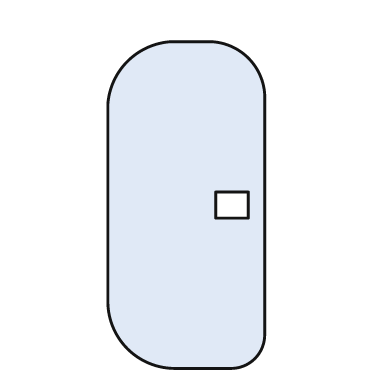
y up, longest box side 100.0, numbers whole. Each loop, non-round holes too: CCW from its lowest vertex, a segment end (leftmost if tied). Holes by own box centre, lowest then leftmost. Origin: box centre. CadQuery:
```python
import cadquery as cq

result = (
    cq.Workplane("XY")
    .moveTo(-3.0, -50.0)
    .lineTo(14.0, -50.0)
    .threePointArc((21.0, -47.0), (24.0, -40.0))
    .lineTo(24.0, 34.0)
    .threePointArc((19.0, 45.0), (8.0, 50.0))
    .lineTo(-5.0, 50.0)
    .threePointArc((-18.0, 44.0), (-24.0, 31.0))
    .lineTo(-24.0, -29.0)
    .threePointArc((-18.0, -44.0), (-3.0, -50.0))
    .close()
    .moveTo(9.0, -4.0)
    .lineTo(19.0, -4.0)
    .lineTo(19.0, 4.0)
    .lineTo(9.0, 4.0)
    .close()
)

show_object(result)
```